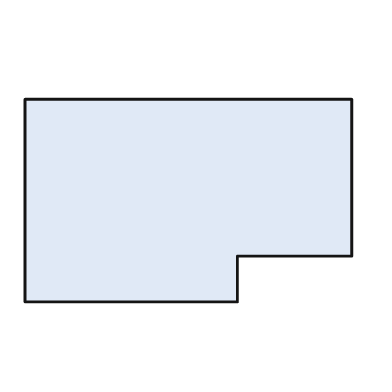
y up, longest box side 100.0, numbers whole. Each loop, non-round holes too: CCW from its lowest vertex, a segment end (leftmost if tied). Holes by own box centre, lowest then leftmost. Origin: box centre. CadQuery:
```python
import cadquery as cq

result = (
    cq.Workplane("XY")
    .moveTo(-50.0, -31.0)
    .lineTo(15.0, -31.0)
    .lineTo(15.0, -17.0)
    .lineTo(50.0, -17.0)
    .lineTo(50.0, 31.0)
    .lineTo(-50.0, 31.0)
    .close()
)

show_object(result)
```